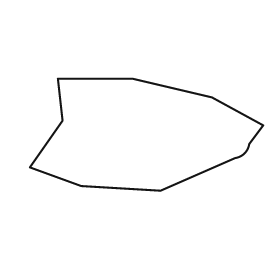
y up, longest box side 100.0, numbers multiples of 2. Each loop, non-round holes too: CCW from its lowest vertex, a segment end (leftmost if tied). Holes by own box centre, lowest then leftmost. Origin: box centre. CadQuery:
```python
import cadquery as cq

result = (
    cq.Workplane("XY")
    .moveTo(6.0, -24.0)
    .lineTo(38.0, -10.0)
    .threePointArc((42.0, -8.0), (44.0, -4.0))
    .lineTo(50.0, 4.0)
    .lineTo(28.0, 16.0)
    .lineTo(-6.0, 24.0)
    .lineTo(-38.0, 24.0)
    .lineTo(-36.0, 6.0)
    .lineTo(-50.0, -14.0)
    .lineTo(-28.0, -22.0)
    .close()
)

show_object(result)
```